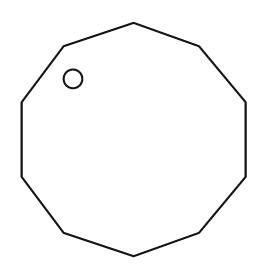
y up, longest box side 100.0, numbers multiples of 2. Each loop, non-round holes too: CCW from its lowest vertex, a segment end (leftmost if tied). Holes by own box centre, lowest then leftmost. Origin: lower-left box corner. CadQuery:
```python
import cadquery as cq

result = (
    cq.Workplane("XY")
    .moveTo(48.0, 0.0)
    .lineTo(76.0, 10.0)
    .lineTo(96.0, 34.0)
    .lineTo(96.0, 66.0)
    .lineTo(76.0, 90.0)
    .lineTo(48.0, 100.0)
    .lineTo(18.0, 90.0)
    .lineTo(0.0, 66.0)
    .lineTo(0.0, 34.0)
    .lineTo(18.0, 10.0)
    .close()
    .moveTo(22.0, 76.0)
    .circle(4.0)
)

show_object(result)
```